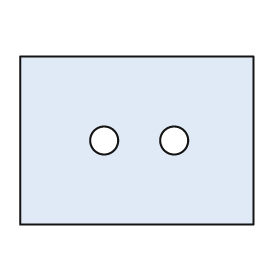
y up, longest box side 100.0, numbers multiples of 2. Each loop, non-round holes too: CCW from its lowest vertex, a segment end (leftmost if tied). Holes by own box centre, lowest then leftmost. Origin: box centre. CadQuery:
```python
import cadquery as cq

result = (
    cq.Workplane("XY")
    .moveTo(-50.0, -36.0)
    .lineTo(50.0, -36.0)
    .lineTo(50.0, 36.0)
    .lineTo(-50.0, 36.0)
    .close()
    .moveTo(-14.0, 0.0)
    .circle(6.0)
    .moveTo(16.0, 0.0)
    .circle(6.0)
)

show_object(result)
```